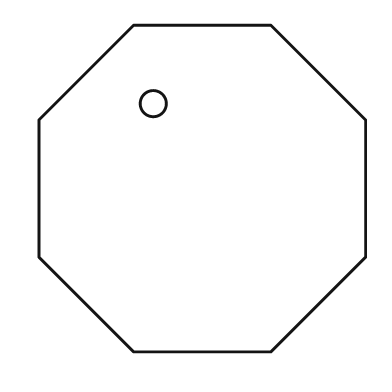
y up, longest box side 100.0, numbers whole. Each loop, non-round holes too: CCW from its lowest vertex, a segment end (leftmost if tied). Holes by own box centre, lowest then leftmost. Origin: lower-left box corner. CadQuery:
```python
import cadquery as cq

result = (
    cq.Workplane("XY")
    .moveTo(29.0, 0.0)
    .lineTo(71.0, 0.0)
    .lineTo(100.0, 29.0)
    .lineTo(100.0, 71.0)
    .lineTo(71.0, 100.0)
    .lineTo(29.0, 100.0)
    .lineTo(0.0, 71.0)
    .lineTo(0.0, 29.0)
    .close()
    .moveTo(35.0, 76.0)
    .circle(4.0)
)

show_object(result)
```